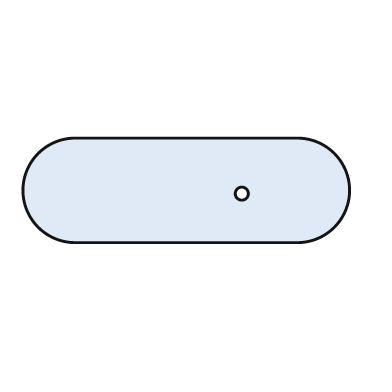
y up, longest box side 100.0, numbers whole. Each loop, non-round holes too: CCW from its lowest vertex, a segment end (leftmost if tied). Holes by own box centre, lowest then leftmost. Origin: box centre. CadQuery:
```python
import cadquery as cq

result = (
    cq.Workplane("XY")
    .moveTo(-34.0, -16.0)
    .lineTo(34.0, -16.0)
    .threePointArc((50.0, 0.0), (34.0, 16.0))
    .lineTo(-34.0, 16.0)
    .threePointArc((-50.0, 0.0), (-34.0, -16.0))
    .close()
    .moveTo(17.0, -1.0)
    .circle(2.0)
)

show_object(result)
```